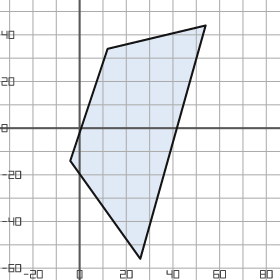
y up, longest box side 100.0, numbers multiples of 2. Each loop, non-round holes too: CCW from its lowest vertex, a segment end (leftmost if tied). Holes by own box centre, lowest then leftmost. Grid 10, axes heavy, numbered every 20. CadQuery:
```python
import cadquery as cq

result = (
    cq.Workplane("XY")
    .moveTo(26.0, -56.0)
    .lineTo(54.0, 44.0)
    .lineTo(12.0, 34.0)
    .lineTo(-4.0, -14.0)
    .close()
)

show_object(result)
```